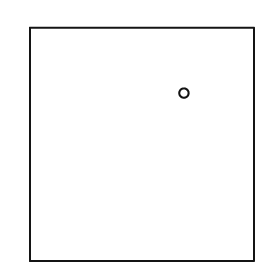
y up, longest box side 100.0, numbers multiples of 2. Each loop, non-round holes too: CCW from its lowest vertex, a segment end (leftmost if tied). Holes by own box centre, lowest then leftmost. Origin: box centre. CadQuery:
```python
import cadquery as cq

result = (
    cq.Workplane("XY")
    .moveTo(-48.0, -50.0)
    .lineTo(48.0, -50.0)
    .lineTo(48.0, 50.0)
    .lineTo(-48.0, 50.0)
    .close()
    .moveTo(18.0, 22.0)
    .circle(2.0)
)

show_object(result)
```